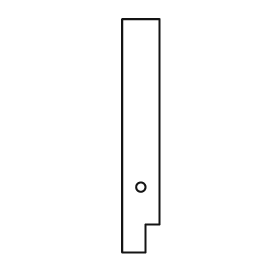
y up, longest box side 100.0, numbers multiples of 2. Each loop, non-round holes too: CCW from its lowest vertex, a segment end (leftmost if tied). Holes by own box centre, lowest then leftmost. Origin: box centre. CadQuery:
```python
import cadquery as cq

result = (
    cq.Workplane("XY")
    .moveTo(-8.0, -50.0)
    .lineTo(2.0, -50.0)
    .lineTo(2.0, -38.0)
    .lineTo(8.0, -38.0)
    .lineTo(8.0, 50.0)
    .lineTo(-8.0, 50.0)
    .close()
    .moveTo(0.0, -22.0)
    .circle(2.0)
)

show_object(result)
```